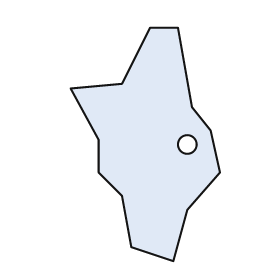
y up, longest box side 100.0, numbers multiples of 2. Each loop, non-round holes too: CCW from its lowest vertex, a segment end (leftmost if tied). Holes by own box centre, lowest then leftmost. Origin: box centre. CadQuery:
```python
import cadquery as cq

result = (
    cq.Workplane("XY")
    .moveTo(12.0, -50.0)
    .lineTo(18.0, -28.0)
    .lineTo(32.0, -12.0)
    .lineTo(28.0, 6.0)
    .lineTo(20.0, 16.0)
    .lineTo(14.0, 50.0)
    .lineTo(2.0, 50.0)
    .lineTo(-10.0, 26.0)
    .lineTo(-32.0, 24.0)
    .lineTo(-20.0, 2.0)
    .lineTo(-20.0, -12.0)
    .lineTo(-10.0, -22.0)
    .lineTo(-6.0, -44.0)
    .close()
    .moveTo(18.0, 0.0)
    .circle(4.0)
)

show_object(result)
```